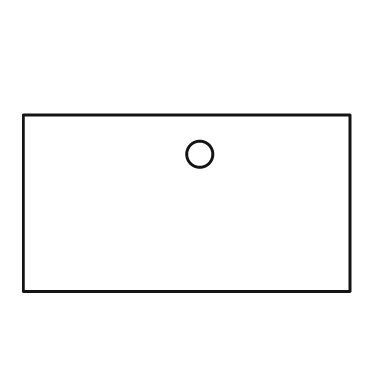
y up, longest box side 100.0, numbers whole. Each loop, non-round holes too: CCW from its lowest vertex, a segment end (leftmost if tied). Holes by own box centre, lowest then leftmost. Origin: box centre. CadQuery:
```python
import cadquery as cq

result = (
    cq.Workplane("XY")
    .moveTo(-50.0, -27.0)
    .lineTo(50.0, -27.0)
    .lineTo(50.0, 27.0)
    .lineTo(-50.0, 27.0)
    .close()
    .moveTo(4.0, 15.0)
    .circle(4.0)
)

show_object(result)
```